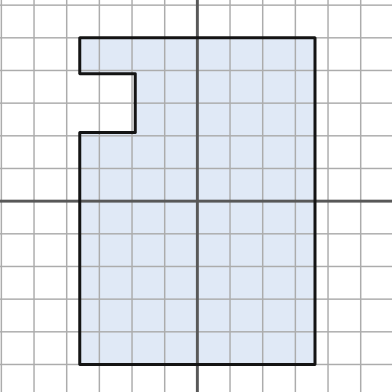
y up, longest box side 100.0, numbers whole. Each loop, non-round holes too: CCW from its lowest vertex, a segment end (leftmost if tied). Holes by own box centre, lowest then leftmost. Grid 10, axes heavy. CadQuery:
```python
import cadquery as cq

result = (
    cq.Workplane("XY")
    .moveTo(-36.0, -50.0)
    .lineTo(36.0, -50.0)
    .lineTo(36.0, 50.0)
    .lineTo(-36.0, 50.0)
    .lineTo(-36.0, 39.0)
    .lineTo(-19.0, 39.0)
    .lineTo(-19.0, 21.0)
    .lineTo(-36.0, 21.0)
    .close()
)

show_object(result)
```